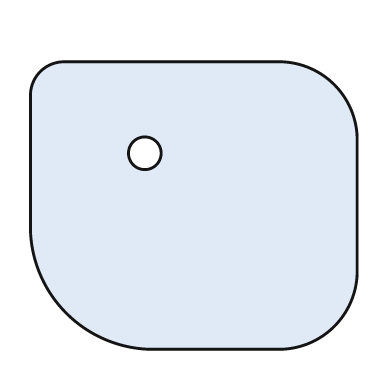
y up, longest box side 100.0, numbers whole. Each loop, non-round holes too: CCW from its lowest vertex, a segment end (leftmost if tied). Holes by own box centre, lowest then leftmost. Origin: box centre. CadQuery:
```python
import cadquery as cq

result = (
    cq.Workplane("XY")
    .moveTo(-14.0, -44.0)
    .lineTo(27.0, -44.0)
    .threePointArc((43.0, -37.0), (50.0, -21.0))
    .lineTo(50.0, 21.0)
    .threePointArc((43.0, 37.0), (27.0, 44.0))
    .lineTo(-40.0, 44.0)
    .threePointArc((-47.0, 41.0), (-50.0, 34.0))
    .lineTo(-50.0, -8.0)
    .threePointArc((-39.0, -33.0), (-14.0, -44.0))
    .close()
    .moveTo(-15.0, 16.0)
    .circle(5.0)
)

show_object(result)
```